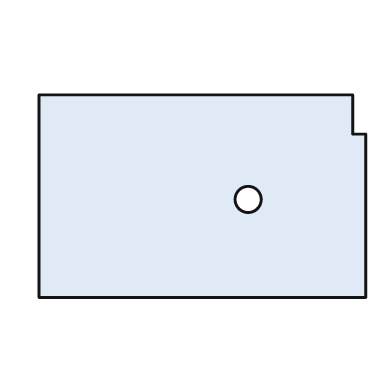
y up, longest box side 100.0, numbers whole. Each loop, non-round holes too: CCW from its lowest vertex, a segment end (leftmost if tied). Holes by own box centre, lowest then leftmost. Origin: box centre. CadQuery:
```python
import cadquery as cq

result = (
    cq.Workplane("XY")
    .moveTo(-50.0, -31.0)
    .lineTo(50.0, -31.0)
    .lineTo(50.0, 19.0)
    .lineTo(46.0, 19.0)
    .lineTo(46.0, 31.0)
    .lineTo(-50.0, 31.0)
    .close()
    .moveTo(14.0, -1.0)
    .circle(4.0)
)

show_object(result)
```